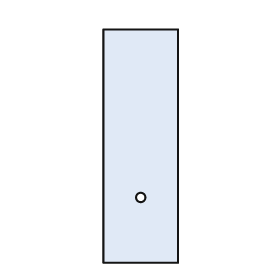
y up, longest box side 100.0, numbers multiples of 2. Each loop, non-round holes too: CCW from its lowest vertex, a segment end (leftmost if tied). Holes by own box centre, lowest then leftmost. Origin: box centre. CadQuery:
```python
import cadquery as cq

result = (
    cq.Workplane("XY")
    .moveTo(-16.0, -50.0)
    .lineTo(16.0, -50.0)
    .lineTo(16.0, 50.0)
    .lineTo(-16.0, 50.0)
    .close()
    .moveTo(0.0, -22.0)
    .circle(2.0)
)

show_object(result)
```